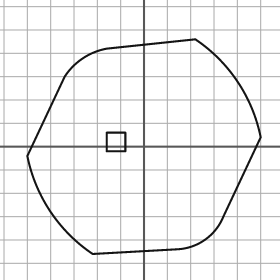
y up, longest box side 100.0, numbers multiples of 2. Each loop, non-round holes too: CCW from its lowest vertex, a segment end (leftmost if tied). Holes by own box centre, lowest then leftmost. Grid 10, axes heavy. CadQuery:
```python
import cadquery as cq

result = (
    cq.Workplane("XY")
    .moveTo(-22.0, -46.0)
    .lineTo(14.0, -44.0)
    .threePointArc((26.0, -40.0), (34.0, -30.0))
    .lineTo(50.0, 4.0)
    .threePointArc((40.0, 28.0), (22.0, 46.0))
    .lineTo(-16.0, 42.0)
    .threePointArc((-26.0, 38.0), (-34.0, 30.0))
    .lineTo(-50.0, -4.0)
    .threePointArc((-40.0, -28.0), (-22.0, -46.0))
    .close()
    .moveTo(-16.0, -2.0)
    .lineTo(-8.0, -2.0)
    .lineTo(-8.0, 6.0)
    .lineTo(-16.0, 6.0)
    .close()
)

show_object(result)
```